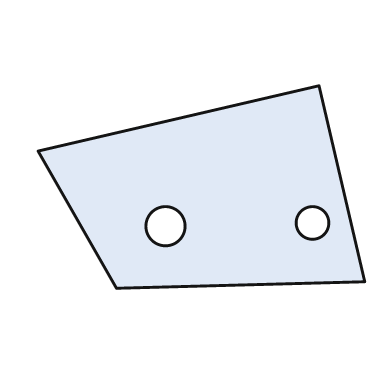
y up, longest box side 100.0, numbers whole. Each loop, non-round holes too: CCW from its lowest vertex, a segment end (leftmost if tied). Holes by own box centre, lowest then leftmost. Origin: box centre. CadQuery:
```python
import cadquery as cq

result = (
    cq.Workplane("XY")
    .moveTo(-26.0, -31.0)
    .lineTo(50.0, -29.0)
    .lineTo(36.0, 31.0)
    .lineTo(-50.0, 11.0)
    .close()
    .moveTo(-11.0, -12.0)
    .circle(6.0)
    .moveTo(34.0, -11.0)
    .circle(5.0)
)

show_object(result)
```